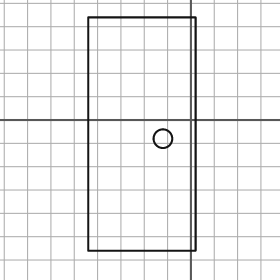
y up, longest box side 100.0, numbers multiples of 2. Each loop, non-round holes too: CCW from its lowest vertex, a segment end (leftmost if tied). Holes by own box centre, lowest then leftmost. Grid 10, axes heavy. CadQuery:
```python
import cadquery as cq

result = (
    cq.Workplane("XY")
    .moveTo(-44.0, -56.0)
    .lineTo(2.0, -56.0)
    .lineTo(2.0, 44.0)
    .lineTo(-44.0, 44.0)
    .close()
    .moveTo(-12.0, -8.0)
    .circle(4.0)
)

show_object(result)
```